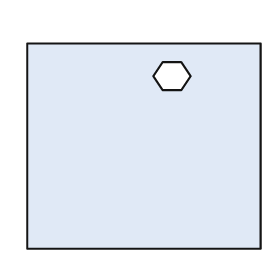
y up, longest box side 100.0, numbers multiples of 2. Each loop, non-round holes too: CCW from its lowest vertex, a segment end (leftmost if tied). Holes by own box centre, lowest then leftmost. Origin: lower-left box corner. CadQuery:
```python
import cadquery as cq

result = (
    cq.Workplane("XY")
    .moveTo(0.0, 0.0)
    .lineTo(100.0, 0.0)
    .lineTo(100.0, 88.0)
    .lineTo(0.0, 88.0)
    .close()
    .moveTo(58.0, 68.0)
    .lineTo(66.0, 68.0)
    .lineTo(70.0, 74.0)
    .lineTo(66.0, 80.0)
    .lineTo(58.0, 80.0)
    .lineTo(54.0, 74.0)
    .close()
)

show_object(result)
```